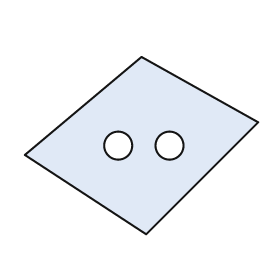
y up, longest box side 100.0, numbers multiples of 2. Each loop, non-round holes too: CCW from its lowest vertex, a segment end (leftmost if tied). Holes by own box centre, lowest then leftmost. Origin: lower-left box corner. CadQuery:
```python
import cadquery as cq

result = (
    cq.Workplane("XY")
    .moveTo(52.0, 0.0)
    .lineTo(100.0, 48.0)
    .lineTo(50.0, 76.0)
    .lineTo(0.0, 34.0)
    .close()
    .moveTo(40.0, 38.0)
    .circle(6.0)
    .moveTo(62.0, 38.0)
    .circle(6.0)
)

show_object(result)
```